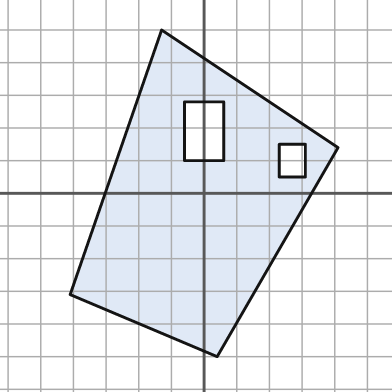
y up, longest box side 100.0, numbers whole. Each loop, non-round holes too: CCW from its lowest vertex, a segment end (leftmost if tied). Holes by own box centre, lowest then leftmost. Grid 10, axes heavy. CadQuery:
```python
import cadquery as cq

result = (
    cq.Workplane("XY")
    .moveTo(4.0, -50.0)
    .lineTo(41.0, 14.0)
    .lineTo(-13.0, 50.0)
    .lineTo(-41.0, -31.0)
    .close()
    .moveTo(23.0, 5.0)
    .lineTo(31.0, 5.0)
    .lineTo(31.0, 15.0)
    .lineTo(23.0, 15.0)
    .close()
    .moveTo(-6.0, 10.0)
    .lineTo(6.0, 10.0)
    .lineTo(6.0, 28.0)
    .lineTo(-6.0, 28.0)
    .close()
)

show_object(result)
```